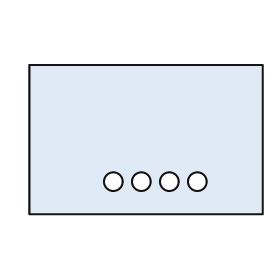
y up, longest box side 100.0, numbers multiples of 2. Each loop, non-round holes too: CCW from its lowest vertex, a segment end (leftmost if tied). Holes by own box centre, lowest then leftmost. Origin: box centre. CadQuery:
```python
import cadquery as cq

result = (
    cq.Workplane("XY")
    .moveTo(-50.0, -32.0)
    .lineTo(50.0, -32.0)
    .lineTo(50.0, 32.0)
    .lineTo(-50.0, 32.0)
    .close()
    .moveTo(-14.0, -18.0)
    .circle(4.0)
    .moveTo(-2.0, -18.0)
    .circle(4.0)
    .moveTo(10.0, -18.0)
    .circle(4.0)
    .moveTo(22.0, -18.0)
    .circle(4.0)
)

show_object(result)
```